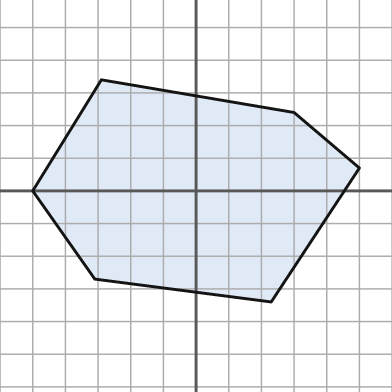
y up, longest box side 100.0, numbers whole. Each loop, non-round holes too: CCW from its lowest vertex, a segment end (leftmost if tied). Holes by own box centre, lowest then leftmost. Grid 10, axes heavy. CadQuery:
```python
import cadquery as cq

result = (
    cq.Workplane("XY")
    .moveTo(23.0, -34.0)
    .lineTo(50.0, 7.0)
    .lineTo(30.0, 24.0)
    .lineTo(-29.0, 34.0)
    .lineTo(-50.0, 0.0)
    .lineTo(-31.0, -27.0)
    .close()
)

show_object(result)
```